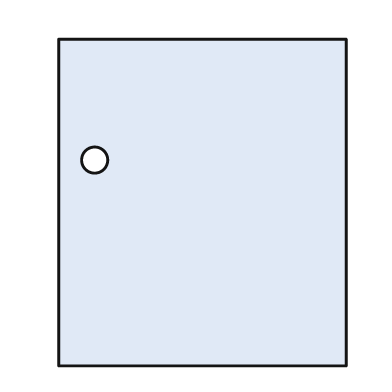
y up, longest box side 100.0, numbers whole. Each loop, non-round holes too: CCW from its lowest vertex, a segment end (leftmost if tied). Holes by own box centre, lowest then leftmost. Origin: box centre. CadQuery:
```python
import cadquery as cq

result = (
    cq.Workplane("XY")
    .moveTo(-44.0, -50.0)
    .lineTo(44.0, -50.0)
    .lineTo(44.0, 50.0)
    .lineTo(-44.0, 50.0)
    .close()
    .moveTo(-33.0, 13.0)
    .circle(4.0)
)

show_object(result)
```